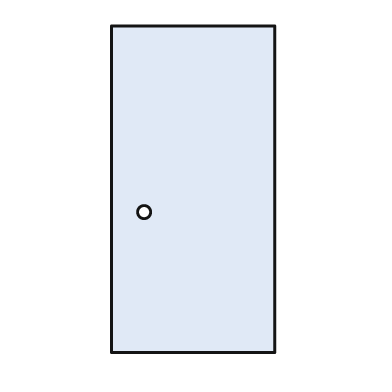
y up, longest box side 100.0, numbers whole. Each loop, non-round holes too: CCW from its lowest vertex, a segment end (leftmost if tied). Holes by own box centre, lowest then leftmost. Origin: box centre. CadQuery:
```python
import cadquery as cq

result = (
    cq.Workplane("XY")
    .moveTo(-25.0, -50.0)
    .lineTo(25.0, -50.0)
    .lineTo(25.0, 50.0)
    .lineTo(-25.0, 50.0)
    .close()
    .moveTo(-15.0, -7.0)
    .circle(2.0)
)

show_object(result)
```